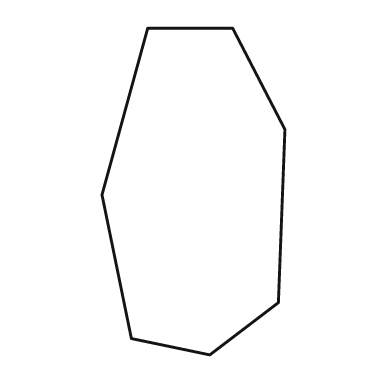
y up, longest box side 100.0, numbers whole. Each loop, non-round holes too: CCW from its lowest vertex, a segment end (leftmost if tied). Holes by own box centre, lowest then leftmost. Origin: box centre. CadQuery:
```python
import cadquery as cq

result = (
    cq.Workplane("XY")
    .moveTo(5.0, -50.0)
    .lineTo(26.0, -34.0)
    .lineTo(28.0, 19.0)
    .lineTo(12.0, 50.0)
    .lineTo(-14.0, 50.0)
    .lineTo(-28.0, -1.0)
    .lineTo(-19.0, -45.0)
    .close()
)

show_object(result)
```